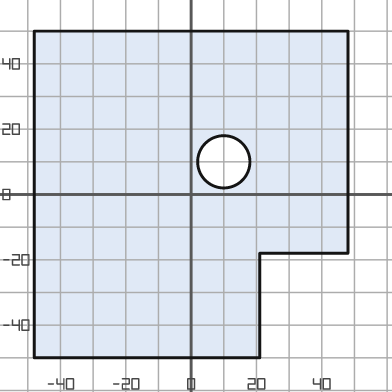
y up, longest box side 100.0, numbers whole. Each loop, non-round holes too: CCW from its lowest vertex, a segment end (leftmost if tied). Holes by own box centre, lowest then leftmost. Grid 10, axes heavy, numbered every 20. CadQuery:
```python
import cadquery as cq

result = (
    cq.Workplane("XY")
    .moveTo(-48.0, -50.0)
    .lineTo(21.0, -50.0)
    .lineTo(21.0, -18.0)
    .lineTo(48.0, -18.0)
    .lineTo(48.0, 50.0)
    .lineTo(-48.0, 50.0)
    .close()
    .moveTo(10.0, 10.0)
    .circle(8.0)
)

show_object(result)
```